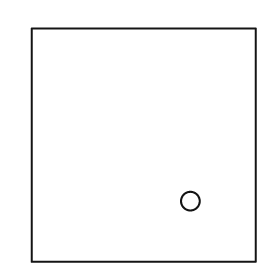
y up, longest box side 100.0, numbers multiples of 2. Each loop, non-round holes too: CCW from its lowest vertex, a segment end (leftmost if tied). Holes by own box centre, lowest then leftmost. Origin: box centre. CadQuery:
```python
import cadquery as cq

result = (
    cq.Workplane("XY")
    .moveTo(-48.0, -50.0)
    .lineTo(48.0, -50.0)
    .lineTo(48.0, 50.0)
    .lineTo(-48.0, 50.0)
    .close()
    .moveTo(20.0, -24.0)
    .circle(4.0)
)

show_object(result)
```